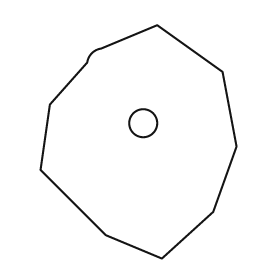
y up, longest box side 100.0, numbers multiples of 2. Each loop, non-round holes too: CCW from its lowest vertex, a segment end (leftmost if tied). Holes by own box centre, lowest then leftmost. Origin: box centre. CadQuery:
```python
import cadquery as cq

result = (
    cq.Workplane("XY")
    .moveTo(10.0, -50.0)
    .lineTo(32.0, -30.0)
    .lineTo(42.0, -2.0)
    .lineTo(36.0, 30.0)
    .lineTo(8.0, 50.0)
    .lineTo(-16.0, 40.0)
    .threePointArc((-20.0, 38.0), (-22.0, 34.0))
    .lineTo(-38.0, 16.0)
    .lineTo(-42.0, -12.0)
    .lineTo(-14.0, -40.0)
    .close()
    .moveTo(2.0, 8.0)
    .circle(6.0)
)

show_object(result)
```